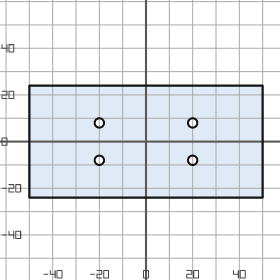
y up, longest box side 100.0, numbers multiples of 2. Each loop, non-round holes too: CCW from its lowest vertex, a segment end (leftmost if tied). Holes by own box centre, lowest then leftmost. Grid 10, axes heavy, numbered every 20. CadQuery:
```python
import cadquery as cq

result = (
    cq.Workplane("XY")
    .moveTo(-50.0, -24.0)
    .lineTo(50.0, -24.0)
    .lineTo(50.0, 24.0)
    .lineTo(-50.0, 24.0)
    .close()
    .moveTo(-20.0, -8.0)
    .circle(2.0)
    .moveTo(20.0, -8.0)
    .circle(2.0)
    .moveTo(-20.0, 8.0)
    .circle(2.0)
    .moveTo(20.0, 8.0)
    .circle(2.0)
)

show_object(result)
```